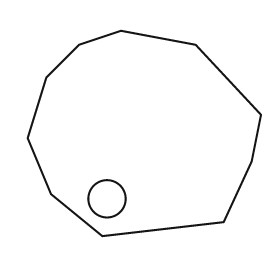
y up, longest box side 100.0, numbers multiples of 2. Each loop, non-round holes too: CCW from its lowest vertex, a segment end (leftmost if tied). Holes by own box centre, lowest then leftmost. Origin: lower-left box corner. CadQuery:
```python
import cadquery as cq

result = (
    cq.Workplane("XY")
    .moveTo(32.0, 0.0)
    .lineTo(84.0, 6.0)
    .lineTo(96.0, 32.0)
    .lineTo(100.0, 52.0)
    .lineTo(72.0, 82.0)
    .lineTo(40.0, 88.0)
    .lineTo(22.0, 82.0)
    .lineTo(8.0, 68.0)
    .lineTo(0.0, 42.0)
    .lineTo(10.0, 18.0)
    .close()
    .moveTo(34.0, 16.0)
    .circle(8.0)
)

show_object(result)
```